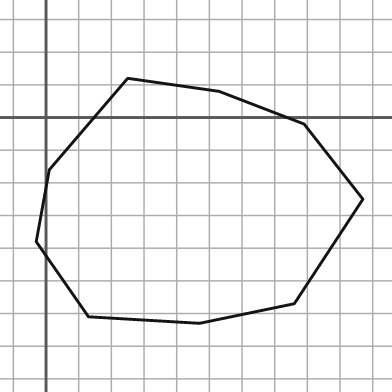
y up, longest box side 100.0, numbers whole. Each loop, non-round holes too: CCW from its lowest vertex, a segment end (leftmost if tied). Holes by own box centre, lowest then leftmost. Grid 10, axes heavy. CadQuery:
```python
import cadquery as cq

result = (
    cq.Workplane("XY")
    .moveTo(47.0, -63.0)
    .lineTo(76.0, -57.0)
    .lineTo(97.0, -25.0)
    .lineTo(79.0, -2.0)
    .lineTo(53.0, 8.0)
    .lineTo(25.0, 12.0)
    .lineTo(1.0, -16.0)
    .lineTo(-3.0, -38.0)
    .lineTo(13.0, -61.0)
    .close()
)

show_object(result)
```